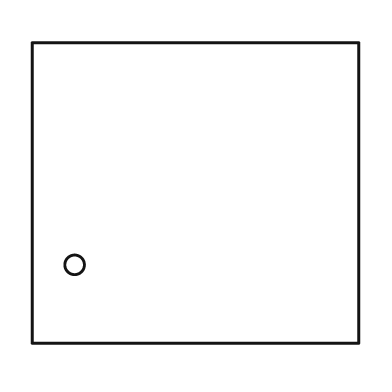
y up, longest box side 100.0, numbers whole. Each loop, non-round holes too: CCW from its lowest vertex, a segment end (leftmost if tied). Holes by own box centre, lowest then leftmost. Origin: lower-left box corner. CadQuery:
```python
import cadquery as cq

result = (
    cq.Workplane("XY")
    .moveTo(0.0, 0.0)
    .lineTo(100.0, 0.0)
    .lineTo(100.0, 92.0)
    .lineTo(0.0, 92.0)
    .close()
    .moveTo(13.0, 24.0)
    .circle(3.0)
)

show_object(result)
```